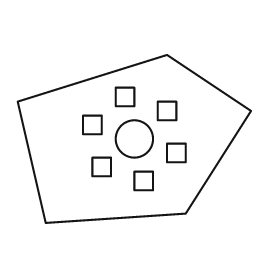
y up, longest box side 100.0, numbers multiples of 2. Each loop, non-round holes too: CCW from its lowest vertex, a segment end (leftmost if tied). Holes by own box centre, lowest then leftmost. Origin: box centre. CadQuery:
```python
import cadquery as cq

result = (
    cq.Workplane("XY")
    .moveTo(-38.0, -36.0)
    .lineTo(22.0, -32.0)
    .lineTo(50.0, 12.0)
    .lineTo(14.0, 36.0)
    .lineTo(-50.0, 16.0)
    .close()
    .moveTo(0.0, -22.0)
    .lineTo(8.0, -22.0)
    .lineTo(8.0, -14.0)
    .lineTo(0.0, -14.0)
    .close()
    .moveTo(-18.0, -16.0)
    .lineTo(-10.0, -16.0)
    .lineTo(-10.0, -8.0)
    .lineTo(-18.0, -8.0)
    .close()
    .moveTo(14.0, -10.0)
    .lineTo(22.0, -10.0)
    .lineTo(22.0, -2.0)
    .lineTo(14.0, -2.0)
    .close()
    .moveTo(0.0, 0.0)
    .circle(8.0)
    .moveTo(-22.0, 2.0)
    .lineTo(-14.0, 2.0)
    .lineTo(-14.0, 10.0)
    .lineTo(-22.0, 10.0)
    .close()
    .moveTo(10.0, 8.0)
    .lineTo(18.0, 8.0)
    .lineTo(18.0, 16.0)
    .lineTo(10.0, 16.0)
    .close()
    .moveTo(-8.0, 14.0)
    .lineTo(0.0, 14.0)
    .lineTo(0.0, 22.0)
    .lineTo(-8.0, 22.0)
    .close()
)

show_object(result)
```